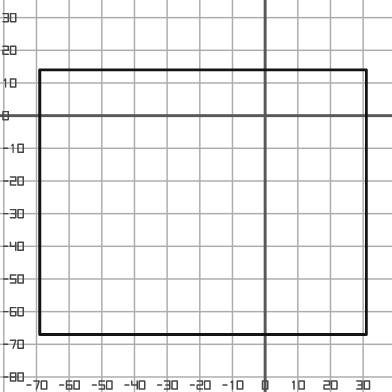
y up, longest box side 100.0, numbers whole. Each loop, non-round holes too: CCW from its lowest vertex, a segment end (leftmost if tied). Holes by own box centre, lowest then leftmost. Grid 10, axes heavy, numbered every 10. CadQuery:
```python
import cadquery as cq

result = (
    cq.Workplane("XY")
    .moveTo(-69.0, -67.0)
    .lineTo(31.0, -67.0)
    .lineTo(31.0, 14.0)
    .lineTo(-69.0, 14.0)
    .close()
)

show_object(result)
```